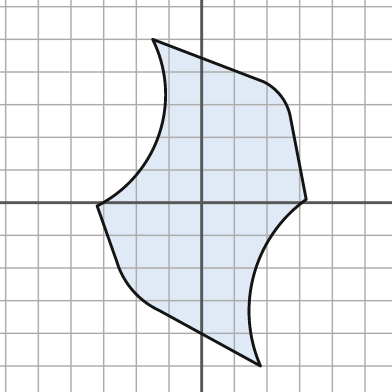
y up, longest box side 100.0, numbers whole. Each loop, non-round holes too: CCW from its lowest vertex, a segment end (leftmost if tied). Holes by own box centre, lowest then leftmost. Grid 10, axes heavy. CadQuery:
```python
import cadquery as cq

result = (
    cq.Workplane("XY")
    .moveTo(18.0, -50.0)
    .threePointArc((16.0, -22.0), (32.0, 1.0))
    .lineTo(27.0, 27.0)
    .threePointArc((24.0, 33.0), (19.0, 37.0))
    .lineTo(-15.0, 50.0)
    .threePointArc((-13.0, 21.0), (-32.0, -1.0))
    .lineTo(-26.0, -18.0)
    .threePointArc((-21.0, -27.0), (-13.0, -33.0))
    .close()
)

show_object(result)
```